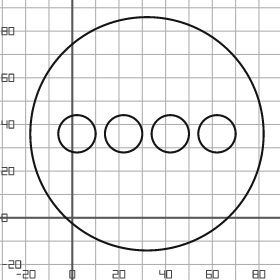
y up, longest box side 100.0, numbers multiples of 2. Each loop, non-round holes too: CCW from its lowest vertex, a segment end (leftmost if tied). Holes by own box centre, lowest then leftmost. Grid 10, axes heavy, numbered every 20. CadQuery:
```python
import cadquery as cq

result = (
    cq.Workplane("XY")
    .moveTo(32.0, 36.0)
    .circle(50.0)
    .moveTo(2.0, 36.0)
    .circle(8.0)
    .moveTo(22.0, 36.0)
    .circle(8.0)
    .moveTo(42.0, 36.0)
    .circle(8.0)
    .moveTo(62.0, 36.0)
    .circle(8.0)
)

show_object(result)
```